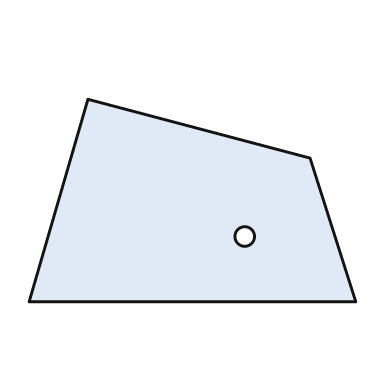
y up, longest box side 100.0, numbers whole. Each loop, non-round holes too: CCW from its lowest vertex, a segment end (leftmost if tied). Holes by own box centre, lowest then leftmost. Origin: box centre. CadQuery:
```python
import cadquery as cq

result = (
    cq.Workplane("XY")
    .moveTo(-50.0, -31.0)
    .lineTo(50.0, -31.0)
    .lineTo(36.0, 13.0)
    .lineTo(-32.0, 31.0)
    .close()
    .moveTo(16.0, -11.0)
    .circle(3.0)
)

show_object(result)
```